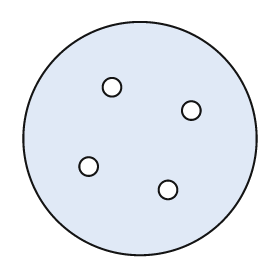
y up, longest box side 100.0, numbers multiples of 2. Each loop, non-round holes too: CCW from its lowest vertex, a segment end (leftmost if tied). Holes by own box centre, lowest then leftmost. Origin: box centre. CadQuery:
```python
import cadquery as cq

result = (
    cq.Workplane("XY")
    .moveTo(0.0, 0.0)
    .circle(50.0)
    .moveTo(12.0, -22.0)
    .circle(4.0)
    .moveTo(-22.0, -12.0)
    .circle(4.0)
    .moveTo(22.0, 12.0)
    .circle(4.0)
    .moveTo(-12.0, 22.0)
    .circle(4.0)
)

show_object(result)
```